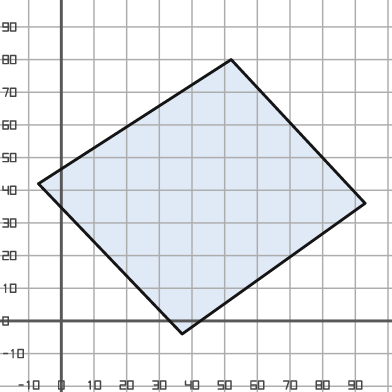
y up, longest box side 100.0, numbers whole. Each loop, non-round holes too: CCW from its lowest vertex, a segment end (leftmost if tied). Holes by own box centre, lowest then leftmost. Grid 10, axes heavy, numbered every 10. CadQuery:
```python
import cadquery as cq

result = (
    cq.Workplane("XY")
    .moveTo(37.0, -4.0)
    .lineTo(93.0, 36.0)
    .lineTo(52.0, 80.0)
    .lineTo(-7.0, 42.0)
    .close()
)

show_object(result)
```